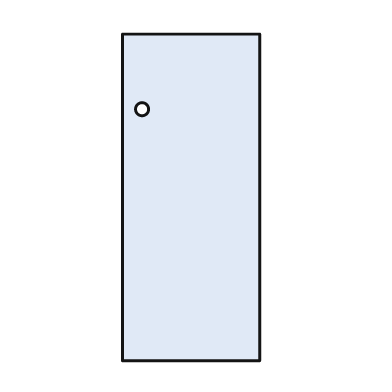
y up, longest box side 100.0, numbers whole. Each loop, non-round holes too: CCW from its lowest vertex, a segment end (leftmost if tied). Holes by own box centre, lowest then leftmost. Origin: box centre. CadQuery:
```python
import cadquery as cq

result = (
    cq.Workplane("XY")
    .moveTo(-21.0, -50.0)
    .lineTo(21.0, -50.0)
    .lineTo(21.0, 50.0)
    .lineTo(-21.0, 50.0)
    .close()
    .moveTo(-15.0, 27.0)
    .circle(2.0)
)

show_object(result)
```